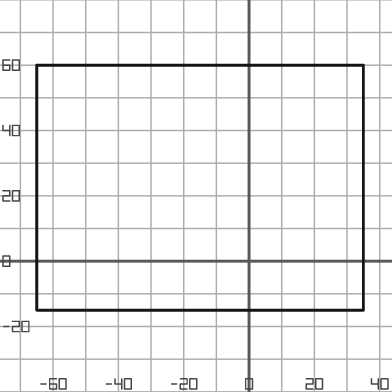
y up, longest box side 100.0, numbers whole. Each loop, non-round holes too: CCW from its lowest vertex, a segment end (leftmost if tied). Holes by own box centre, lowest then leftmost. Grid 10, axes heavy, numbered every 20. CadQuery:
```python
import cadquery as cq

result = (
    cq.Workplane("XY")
    .moveTo(-65.0, -15.0)
    .lineTo(35.0, -15.0)
    .lineTo(35.0, 60.0)
    .lineTo(-65.0, 60.0)
    .close()
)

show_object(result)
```